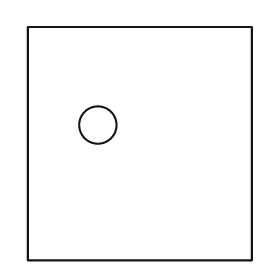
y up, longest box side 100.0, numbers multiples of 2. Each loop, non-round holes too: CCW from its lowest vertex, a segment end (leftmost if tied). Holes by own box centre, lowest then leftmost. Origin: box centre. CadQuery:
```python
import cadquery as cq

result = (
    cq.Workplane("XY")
    .moveTo(-48.0, -50.0)
    .lineTo(48.0, -50.0)
    .lineTo(48.0, 50.0)
    .lineTo(-48.0, 50.0)
    .close()
    .moveTo(-18.0, 8.0)
    .circle(8.0)
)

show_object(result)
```